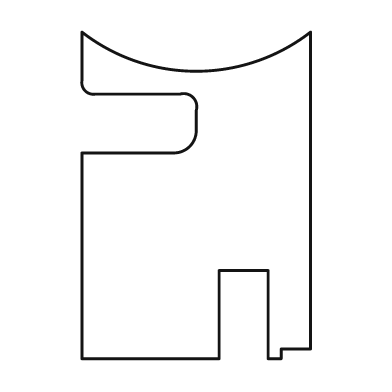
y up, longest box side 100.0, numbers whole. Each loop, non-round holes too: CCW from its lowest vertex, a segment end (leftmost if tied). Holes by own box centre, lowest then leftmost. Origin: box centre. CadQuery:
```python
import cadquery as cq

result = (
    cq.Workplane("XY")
    .moveTo(-35.0, -50.0)
    .lineTo(7.0, -50.0)
    .lineTo(7.0, -23.0)
    .lineTo(22.0, -23.0)
    .lineTo(22.0, -50.0)
    .lineTo(26.0, -50.0)
    .lineTo(26.0, -47.0)
    .lineTo(35.0, -47.0)
    .lineTo(35.0, 50.0)
    .threePointArc((0.0, 38.0), (-35.0, 50.0))
    .lineTo(-35.0, 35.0)
    .threePointArc((-34.0, 32.0), (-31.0, 31.0))
    .lineTo(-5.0, 31.0)
    .threePointArc((-1.0, 30.0), (0.0, 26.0))
    .lineTo(0.0, 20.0)
    .threePointArc((-2.0, 15.0), (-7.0, 13.0))
    .lineTo(-35.0, 13.0)
    .close()
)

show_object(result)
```